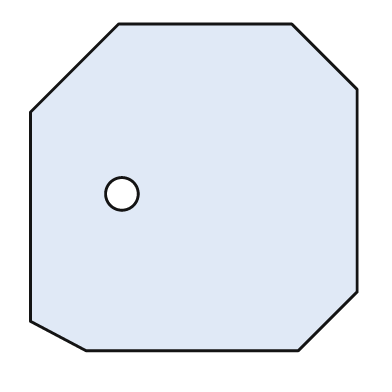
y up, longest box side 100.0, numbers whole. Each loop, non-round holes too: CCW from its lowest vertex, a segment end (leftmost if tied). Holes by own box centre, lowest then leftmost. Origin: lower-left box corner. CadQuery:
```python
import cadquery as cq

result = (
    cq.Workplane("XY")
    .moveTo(17.0, 0.0)
    .lineTo(82.0, 0.0)
    .lineTo(100.0, 18.0)
    .lineTo(100.0, 80.0)
    .lineTo(80.0, 100.0)
    .lineTo(27.0, 100.0)
    .lineTo(0.0, 73.0)
    .lineTo(0.0, 9.0)
    .close()
    .moveTo(28.0, 48.0)
    .circle(5.0)
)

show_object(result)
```